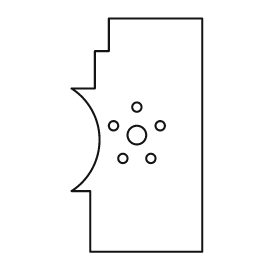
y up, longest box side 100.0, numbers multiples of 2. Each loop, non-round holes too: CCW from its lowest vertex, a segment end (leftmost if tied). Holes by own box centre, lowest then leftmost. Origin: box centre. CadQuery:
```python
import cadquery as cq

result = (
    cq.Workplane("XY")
    .moveTo(-20.0, -50.0)
    .lineTo(28.0, -50.0)
    .lineTo(28.0, 50.0)
    .lineTo(-12.0, 50.0)
    .lineTo(-12.0, 36.0)
    .lineTo(-18.0, 36.0)
    .lineTo(-18.0, 20.0)
    .lineTo(-28.0, 20.0)
    .threePointArc((-16.0, -2.0), (-28.0, -24.0))
    .lineTo(-20.0, -24.0)
    .close()
    .moveTo(-6.0, -10.0)
    .circle(2.0)
    .moveTo(6.0, -10.0)
    .circle(2.0)
    .moveTo(0.0, 0.0)
    .circle(4.0)
    .moveTo(-10.0, 4.0)
    .circle(2.0)
    .moveTo(10.0, 4.0)
    .circle(2.0)
    .moveTo(0.0, 12.0)
    .circle(2.0)
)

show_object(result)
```